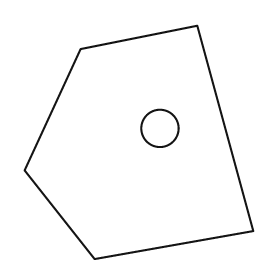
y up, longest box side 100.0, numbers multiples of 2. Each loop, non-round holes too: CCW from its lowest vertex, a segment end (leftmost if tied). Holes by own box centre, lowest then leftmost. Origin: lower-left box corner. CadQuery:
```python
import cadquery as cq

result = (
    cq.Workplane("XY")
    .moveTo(30.0, 0.0)
    .lineTo(98.0, 12.0)
    .lineTo(74.0, 100.0)
    .lineTo(24.0, 90.0)
    .lineTo(0.0, 38.0)
    .close()
    .moveTo(58.0, 56.0)
    .circle(8.0)
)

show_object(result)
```